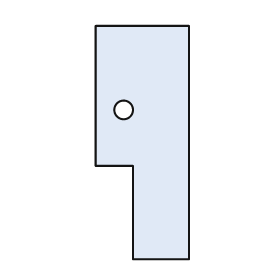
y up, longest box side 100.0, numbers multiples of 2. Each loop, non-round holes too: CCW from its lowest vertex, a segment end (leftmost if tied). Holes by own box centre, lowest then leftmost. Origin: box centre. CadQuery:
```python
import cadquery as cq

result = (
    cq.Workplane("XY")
    .moveTo(-4.0, -50.0)
    .lineTo(20.0, -50.0)
    .lineTo(20.0, 50.0)
    .lineTo(-20.0, 50.0)
    .lineTo(-20.0, -10.0)
    .lineTo(-4.0, -10.0)
    .close()
    .moveTo(-8.0, 14.0)
    .circle(4.0)
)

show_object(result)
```